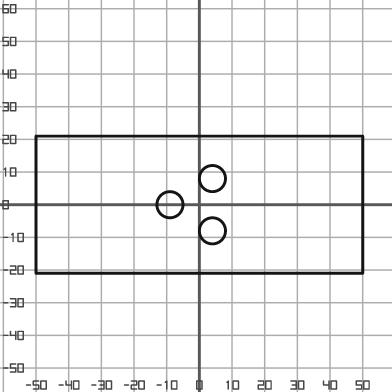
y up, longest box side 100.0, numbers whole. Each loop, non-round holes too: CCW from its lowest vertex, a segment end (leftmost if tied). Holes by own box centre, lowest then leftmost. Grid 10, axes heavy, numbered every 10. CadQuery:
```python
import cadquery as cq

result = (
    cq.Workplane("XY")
    .moveTo(-50.0, -21.0)
    .lineTo(50.0, -21.0)
    .lineTo(50.0, 21.0)
    .lineTo(-50.0, 21.0)
    .close()
    .moveTo(4.0, -8.0)
    .circle(4.0)
    .moveTo(-9.0, 0.0)
    .circle(4.0)
    .moveTo(4.0, 8.0)
    .circle(4.0)
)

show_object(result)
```